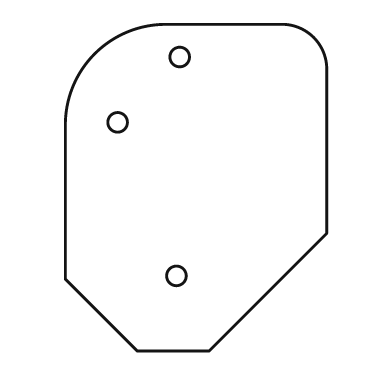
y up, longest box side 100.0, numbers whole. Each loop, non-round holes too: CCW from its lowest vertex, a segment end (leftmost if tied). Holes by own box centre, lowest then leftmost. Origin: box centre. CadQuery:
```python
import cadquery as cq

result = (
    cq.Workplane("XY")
    .moveTo(-18.0, -50.0)
    .lineTo(4.0, -50.0)
    .lineTo(40.0, -14.0)
    .lineTo(40.0, 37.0)
    .threePointArc((36.0, 46.0), (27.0, 50.0))
    .lineTo(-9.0, 50.0)
    .threePointArc((-31.0, 41.0), (-40.0, 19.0))
    .lineTo(-40.0, -28.0)
    .close()
    .moveTo(-6.0, -27.0)
    .circle(3.0)
    .moveTo(-24.0, 20.0)
    .circle(3.0)
    .moveTo(-5.0, 40.0)
    .circle(3.0)
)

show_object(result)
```